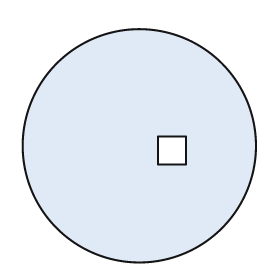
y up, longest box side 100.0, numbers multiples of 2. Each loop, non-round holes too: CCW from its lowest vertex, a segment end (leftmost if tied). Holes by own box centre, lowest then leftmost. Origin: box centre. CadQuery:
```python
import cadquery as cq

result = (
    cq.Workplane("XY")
    .moveTo(0.0, 0.0)
    .circle(50.0)
    .moveTo(8.0, -8.0)
    .lineTo(20.0, -8.0)
    .lineTo(20.0, 4.0)
    .lineTo(8.0, 4.0)
    .close()
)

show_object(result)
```